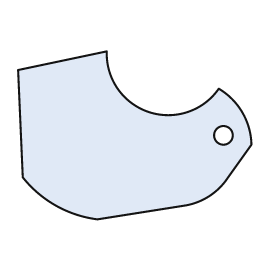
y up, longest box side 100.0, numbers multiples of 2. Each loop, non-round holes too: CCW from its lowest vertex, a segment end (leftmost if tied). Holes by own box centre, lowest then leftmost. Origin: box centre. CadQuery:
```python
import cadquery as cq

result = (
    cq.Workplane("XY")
    .moveTo(-16.0, -36.0)
    .lineTo(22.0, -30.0)
    .threePointArc((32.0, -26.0), (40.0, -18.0))
    .lineTo(50.0, -4.0)
    .threePointArc((46.0, 10.0), (36.0, 20.0))
    .threePointArc((6.0, 10.0), (-12.0, 36.0))
    .lineTo(-50.0, 28.0)
    .lineTo(-48.0, -18.0)
    .threePointArc((-34.0, -30.0), (-16.0, -36.0))
    .close()
    .moveTo(38.0, 0.0)
    .circle(4.0)
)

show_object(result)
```